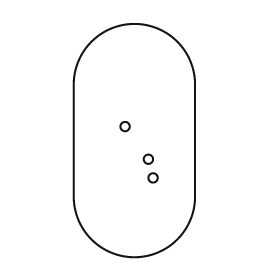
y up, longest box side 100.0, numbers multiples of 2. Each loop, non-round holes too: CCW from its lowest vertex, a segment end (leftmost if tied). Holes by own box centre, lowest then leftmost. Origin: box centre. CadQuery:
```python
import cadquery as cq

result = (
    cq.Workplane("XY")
    .moveTo(-26.0, -24.0)
    .threePointArc((0.0, -50.0), (26.0, -24.0))
    .lineTo(26.0, 24.0)
    .threePointArc((0.0, 50.0), (-26.0, 24.0))
    .close()
    .moveTo(8.0, -16.0)
    .circle(2.0)
    .moveTo(6.0, -8.0)
    .circle(2.0)
    .moveTo(-4.0, 6.0)
    .circle(2.0)
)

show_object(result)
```